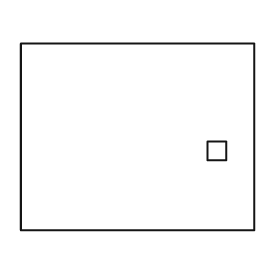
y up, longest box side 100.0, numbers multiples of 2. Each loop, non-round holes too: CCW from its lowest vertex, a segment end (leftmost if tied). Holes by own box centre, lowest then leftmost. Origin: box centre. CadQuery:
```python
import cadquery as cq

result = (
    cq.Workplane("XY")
    .moveTo(-50.0, -40.0)
    .lineTo(50.0, -40.0)
    .lineTo(50.0, 40.0)
    .lineTo(-50.0, 40.0)
    .close()
    .moveTo(30.0, -10.0)
    .lineTo(38.0, -10.0)
    .lineTo(38.0, -2.0)
    .lineTo(30.0, -2.0)
    .close()
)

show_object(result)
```